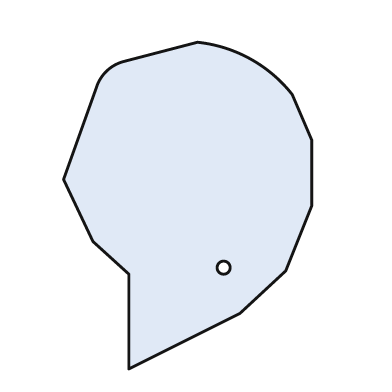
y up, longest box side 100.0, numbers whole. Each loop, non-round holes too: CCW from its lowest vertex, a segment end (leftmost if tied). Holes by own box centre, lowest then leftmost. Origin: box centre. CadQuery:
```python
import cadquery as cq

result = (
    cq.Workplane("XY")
    .moveTo(-18.0, -50.0)
    .lineTo(16.0, -33.0)
    .lineTo(30.0, -20.0)
    .lineTo(38.0, 0.0)
    .lineTo(38.0, 20.0)
    .lineTo(32.0, 34.0)
    .threePointArc((19.0, 45.0), (3.0, 50.0))
    .lineTo(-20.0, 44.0)
    .threePointArc((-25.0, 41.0), (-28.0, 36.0))
    .lineTo(-38.0, 8.0)
    .lineTo(-29.0, -11.0)
    .lineTo(-18.0, -21.0)
    .close()
    .moveTo(11.0, -19.0)
    .circle(2.0)
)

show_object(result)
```